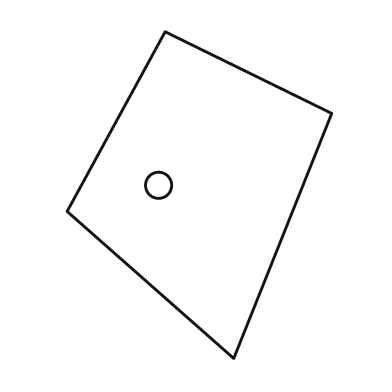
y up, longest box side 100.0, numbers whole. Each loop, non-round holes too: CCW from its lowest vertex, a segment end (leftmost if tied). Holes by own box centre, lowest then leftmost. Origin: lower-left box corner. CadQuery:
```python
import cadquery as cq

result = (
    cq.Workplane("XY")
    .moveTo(51.0, 0.0)
    .lineTo(81.0, 75.0)
    .lineTo(30.0, 100.0)
    .lineTo(0.0, 45.0)
    .close()
    .moveTo(28.0, 53.0)
    .circle(4.0)
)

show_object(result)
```